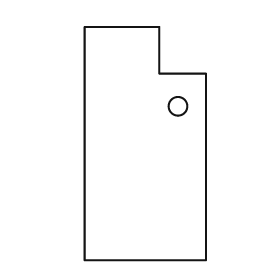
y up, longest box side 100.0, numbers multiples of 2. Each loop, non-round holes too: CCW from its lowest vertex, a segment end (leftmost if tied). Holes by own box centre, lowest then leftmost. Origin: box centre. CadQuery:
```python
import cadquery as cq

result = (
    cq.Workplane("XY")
    .moveTo(-26.0, -50.0)
    .lineTo(26.0, -50.0)
    .lineTo(26.0, 30.0)
    .lineTo(6.0, 30.0)
    .lineTo(6.0, 50.0)
    .lineTo(-26.0, 50.0)
    .close()
    .moveTo(14.0, 16.0)
    .circle(4.0)
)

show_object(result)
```